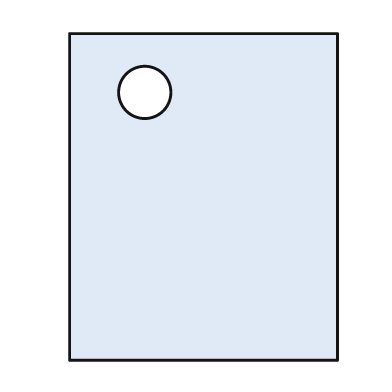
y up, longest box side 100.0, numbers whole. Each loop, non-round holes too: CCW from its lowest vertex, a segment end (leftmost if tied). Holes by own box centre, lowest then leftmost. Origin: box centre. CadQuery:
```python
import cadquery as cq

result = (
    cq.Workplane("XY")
    .moveTo(-41.0, -50.0)
    .lineTo(41.0, -50.0)
    .lineTo(41.0, 50.0)
    .lineTo(-41.0, 50.0)
    .close()
    .moveTo(-18.0, 32.0)
    .circle(8.0)
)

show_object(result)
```